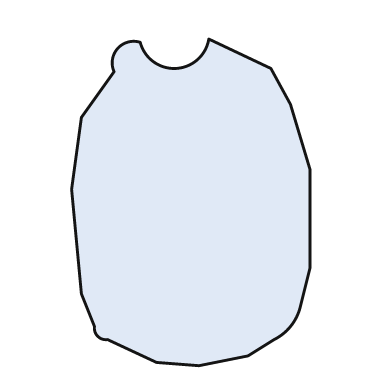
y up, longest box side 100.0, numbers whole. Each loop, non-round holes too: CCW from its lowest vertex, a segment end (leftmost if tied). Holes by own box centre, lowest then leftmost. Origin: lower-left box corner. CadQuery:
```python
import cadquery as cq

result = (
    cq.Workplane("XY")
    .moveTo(39.0, 0.0)
    .lineTo(54.0, 3.0)
    .lineTo(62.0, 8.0)
    .threePointArc((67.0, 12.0), (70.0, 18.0))
    .lineTo(73.0, 30.0)
    .lineTo(73.0, 60.0)
    .lineTo(67.0, 80.0)
    .lineTo(61.0, 91.0)
    .lineTo(42.0, 100.0)
    .threePointArc((32.0, 91.0), (21.0, 99.0))
    .threePointArc((14.0, 97.0), (13.0, 90.0))
    .lineTo(3.0, 76.0)
    .lineTo(0.0, 54.0)
    .lineTo(3.0, 22.0)
    .lineTo(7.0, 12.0)
    .threePointArc((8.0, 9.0), (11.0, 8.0))
    .lineTo(26.0, 1.0)
    .close()
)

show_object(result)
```